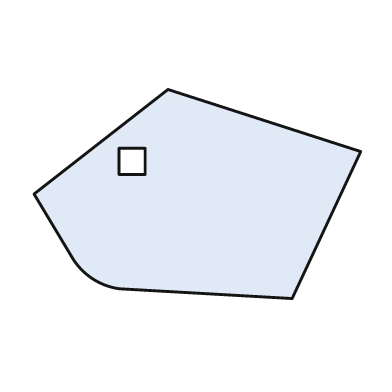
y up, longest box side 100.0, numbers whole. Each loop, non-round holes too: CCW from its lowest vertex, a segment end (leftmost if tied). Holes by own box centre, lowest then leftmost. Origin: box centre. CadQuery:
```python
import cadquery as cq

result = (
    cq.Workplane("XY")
    .moveTo(29.0, -32.0)
    .lineTo(50.0, 13.0)
    .lineTo(-9.0, 32.0)
    .lineTo(-50.0, 0.0)
    .lineTo(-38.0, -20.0)
    .threePointArc((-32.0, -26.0), (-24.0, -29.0))
    .close()
    .moveTo(-24.0, 6.0)
    .lineTo(-16.0, 6.0)
    .lineTo(-16.0, 14.0)
    .lineTo(-24.0, 14.0)
    .close()
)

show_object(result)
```